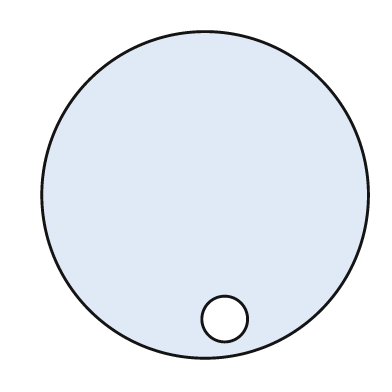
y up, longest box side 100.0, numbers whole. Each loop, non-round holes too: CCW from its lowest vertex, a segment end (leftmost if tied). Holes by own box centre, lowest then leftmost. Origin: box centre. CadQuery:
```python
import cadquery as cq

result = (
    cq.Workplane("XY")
    .moveTo(0.0, 0.0)
    .circle(50.0)
    .moveTo(6.0, -38.0)
    .circle(7.0)
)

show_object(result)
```